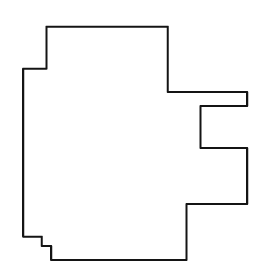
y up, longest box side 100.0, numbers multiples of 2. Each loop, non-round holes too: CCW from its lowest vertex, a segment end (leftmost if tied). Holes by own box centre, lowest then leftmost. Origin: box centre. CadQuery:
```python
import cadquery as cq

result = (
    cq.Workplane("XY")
    .moveTo(-36.0, -50.0)
    .lineTo(22.0, -50.0)
    .lineTo(22.0, -26.0)
    .lineTo(48.0, -26.0)
    .lineTo(48.0, -2.0)
    .lineTo(28.0, -2.0)
    .lineTo(28.0, 16.0)
    .lineTo(48.0, 16.0)
    .lineTo(48.0, 22.0)
    .lineTo(14.0, 22.0)
    .lineTo(14.0, 50.0)
    .lineTo(-38.0, 50.0)
    .lineTo(-38.0, 32.0)
    .lineTo(-48.0, 32.0)
    .lineTo(-48.0, -40.0)
    .lineTo(-40.0, -40.0)
    .lineTo(-40.0, -44.0)
    .lineTo(-36.0, -44.0)
    .close()
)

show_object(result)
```